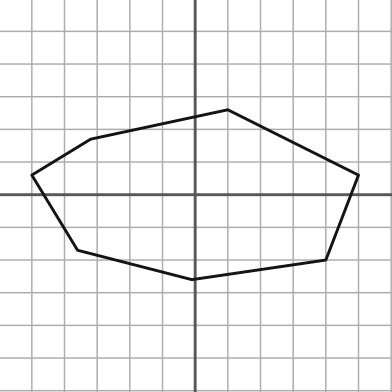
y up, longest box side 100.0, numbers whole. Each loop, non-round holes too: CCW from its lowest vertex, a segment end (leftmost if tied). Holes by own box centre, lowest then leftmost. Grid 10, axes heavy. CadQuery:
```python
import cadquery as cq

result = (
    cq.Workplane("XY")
    .moveTo(-1.0, -26.0)
    .lineTo(40.0, -20.0)
    .lineTo(50.0, 6.0)
    .lineTo(10.0, 26.0)
    .lineTo(-32.0, 17.0)
    .lineTo(-50.0, 6.0)
    .lineTo(-36.0, -17.0)
    .close()
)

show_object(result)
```